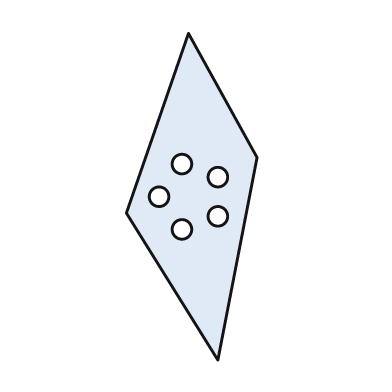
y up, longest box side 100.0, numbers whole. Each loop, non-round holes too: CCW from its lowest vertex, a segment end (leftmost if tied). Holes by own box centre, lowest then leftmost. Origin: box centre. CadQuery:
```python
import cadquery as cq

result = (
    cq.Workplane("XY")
    .moveTo(8.0, -50.0)
    .lineTo(20.0, 12.0)
    .lineTo(-1.0, 50.0)
    .lineTo(-20.0, -5.0)
    .close()
    .moveTo(-3.0, -10.0)
    .circle(3.0)
    .moveTo(8.0, -6.0)
    .circle(3.0)
    .moveTo(-10.0, 0.0)
    .circle(3.0)
    .moveTo(8.0, 6.0)
    .circle(3.0)
    .moveTo(-3.0, 10.0)
    .circle(3.0)
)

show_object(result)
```